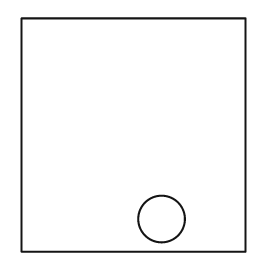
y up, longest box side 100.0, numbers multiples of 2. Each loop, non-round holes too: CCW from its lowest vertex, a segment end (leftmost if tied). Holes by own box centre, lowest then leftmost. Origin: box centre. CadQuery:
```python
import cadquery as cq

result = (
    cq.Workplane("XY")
    .moveTo(-48.0, -50.0)
    .lineTo(48.0, -50.0)
    .lineTo(48.0, 50.0)
    .lineTo(-48.0, 50.0)
    .close()
    .moveTo(12.0, -36.0)
    .circle(10.0)
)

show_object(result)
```